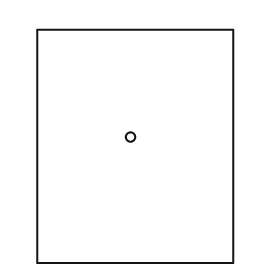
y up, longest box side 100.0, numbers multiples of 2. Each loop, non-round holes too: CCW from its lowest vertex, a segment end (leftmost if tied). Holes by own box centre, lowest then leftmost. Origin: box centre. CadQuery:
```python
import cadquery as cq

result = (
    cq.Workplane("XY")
    .moveTo(-42.0, -50.0)
    .lineTo(42.0, -50.0)
    .lineTo(42.0, 50.0)
    .lineTo(-42.0, 50.0)
    .close()
    .moveTo(-2.0, 4.0)
    .circle(2.0)
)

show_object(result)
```